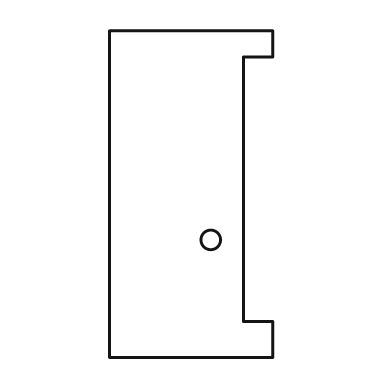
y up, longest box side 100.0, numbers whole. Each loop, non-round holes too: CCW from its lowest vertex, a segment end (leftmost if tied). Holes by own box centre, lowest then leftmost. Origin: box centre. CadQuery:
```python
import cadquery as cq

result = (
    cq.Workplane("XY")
    .moveTo(-25.0, -50.0)
    .lineTo(25.0, -50.0)
    .lineTo(25.0, -39.0)
    .lineTo(16.0, -39.0)
    .lineTo(16.0, 42.0)
    .lineTo(25.0, 42.0)
    .lineTo(25.0, 50.0)
    .lineTo(-25.0, 50.0)
    .close()
    .moveTo(6.0, -14.0)
    .circle(3.0)
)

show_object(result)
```